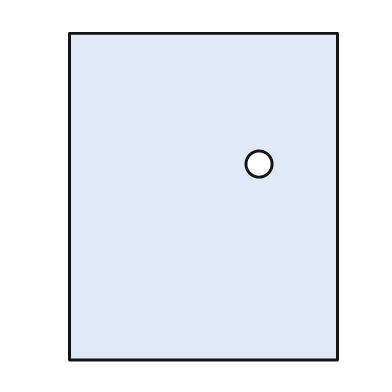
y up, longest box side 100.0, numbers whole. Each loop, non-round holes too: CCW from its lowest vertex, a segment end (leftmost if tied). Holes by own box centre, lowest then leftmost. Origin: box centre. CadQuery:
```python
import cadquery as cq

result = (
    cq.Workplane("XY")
    .moveTo(-41.0, -50.0)
    .lineTo(41.0, -50.0)
    .lineTo(41.0, 50.0)
    .lineTo(-41.0, 50.0)
    .close()
    .moveTo(17.0, 10.0)
    .circle(4.0)
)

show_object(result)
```